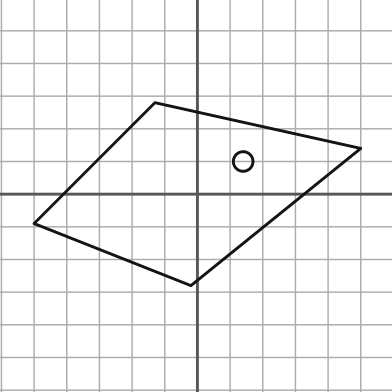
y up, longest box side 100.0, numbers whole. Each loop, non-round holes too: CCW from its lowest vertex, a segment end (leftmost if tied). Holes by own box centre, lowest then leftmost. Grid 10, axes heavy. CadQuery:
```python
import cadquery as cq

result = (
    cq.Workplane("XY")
    .moveTo(-2.0, -28.0)
    .lineTo(50.0, 14.0)
    .lineTo(-13.0, 28.0)
    .lineTo(-50.0, -9.0)
    .close()
    .moveTo(14.0, 10.0)
    .circle(3.0)
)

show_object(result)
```